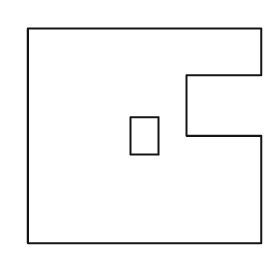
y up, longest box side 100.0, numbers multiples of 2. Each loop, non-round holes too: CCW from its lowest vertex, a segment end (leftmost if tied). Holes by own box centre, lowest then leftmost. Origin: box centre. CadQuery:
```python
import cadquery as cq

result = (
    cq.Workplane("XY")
    .moveTo(-50.0, -46.0)
    .lineTo(50.0, -46.0)
    .lineTo(50.0, 0.0)
    .lineTo(18.0, 0.0)
    .lineTo(18.0, 26.0)
    .lineTo(50.0, 26.0)
    .lineTo(50.0, 46.0)
    .lineTo(-50.0, 46.0)
    .close()
    .moveTo(-6.0, -8.0)
    .lineTo(6.0, -8.0)
    .lineTo(6.0, 8.0)
    .lineTo(-6.0, 8.0)
    .close()
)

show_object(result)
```